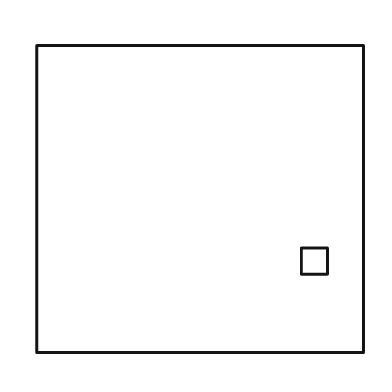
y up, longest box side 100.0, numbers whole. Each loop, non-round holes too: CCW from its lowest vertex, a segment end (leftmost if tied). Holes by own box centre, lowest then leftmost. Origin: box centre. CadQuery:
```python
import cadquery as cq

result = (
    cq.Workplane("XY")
    .moveTo(-50.0, -47.0)
    .lineTo(50.0, -47.0)
    .lineTo(50.0, 47.0)
    .lineTo(-50.0, 47.0)
    .close()
    .moveTo(31.0, -23.0)
    .lineTo(39.0, -23.0)
    .lineTo(39.0, -15.0)
    .lineTo(31.0, -15.0)
    .close()
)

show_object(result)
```